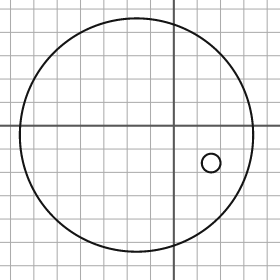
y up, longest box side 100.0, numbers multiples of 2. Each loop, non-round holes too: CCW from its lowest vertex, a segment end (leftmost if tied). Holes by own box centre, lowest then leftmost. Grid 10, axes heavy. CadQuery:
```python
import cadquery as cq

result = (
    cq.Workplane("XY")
    .moveTo(-16.0, -4.0)
    .circle(50.0)
    .moveTo(16.0, -16.0)
    .circle(4.0)
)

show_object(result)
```